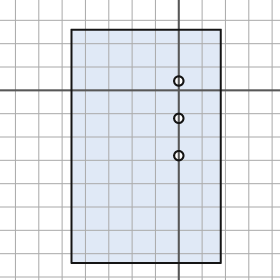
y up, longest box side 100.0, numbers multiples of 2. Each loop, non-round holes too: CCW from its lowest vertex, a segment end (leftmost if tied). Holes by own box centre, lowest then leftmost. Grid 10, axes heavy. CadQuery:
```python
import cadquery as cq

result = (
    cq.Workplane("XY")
    .moveTo(-46.0, -74.0)
    .lineTo(18.0, -74.0)
    .lineTo(18.0, 26.0)
    .lineTo(-46.0, 26.0)
    .close()
    .moveTo(0.0, -28.0)
    .circle(2.0)
    .moveTo(0.0, -12.0)
    .circle(2.0)
    .moveTo(0.0, 4.0)
    .circle(2.0)
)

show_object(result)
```